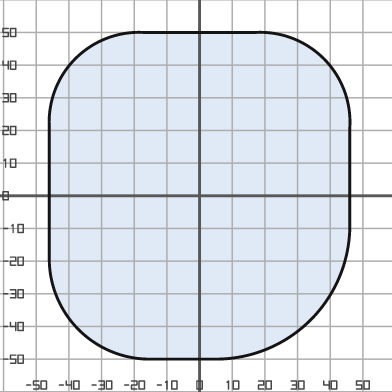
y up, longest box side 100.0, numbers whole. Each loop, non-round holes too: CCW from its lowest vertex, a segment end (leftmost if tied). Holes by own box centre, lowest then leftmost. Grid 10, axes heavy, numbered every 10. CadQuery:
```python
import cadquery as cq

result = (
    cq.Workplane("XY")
    .moveTo(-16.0, -50.0)
    .lineTo(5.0, -50.0)
    .threePointArc((34.0, -38.0), (46.0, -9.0))
    .lineTo(46.0, 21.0)
    .threePointArc((38.0, 42.0), (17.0, 50.0))
    .lineTo(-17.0, 50.0)
    .threePointArc((-38.0, 42.0), (-46.0, 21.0))
    .lineTo(-46.0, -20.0)
    .threePointArc((-37.0, -41.0), (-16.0, -50.0))
    .close()
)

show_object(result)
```